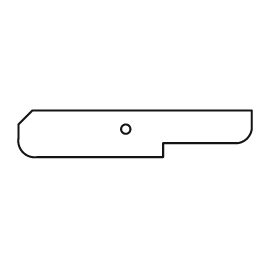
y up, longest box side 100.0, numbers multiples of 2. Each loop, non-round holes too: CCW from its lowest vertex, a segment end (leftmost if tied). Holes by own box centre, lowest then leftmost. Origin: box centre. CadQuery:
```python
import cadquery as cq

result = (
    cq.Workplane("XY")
    .moveTo(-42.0, -10.0)
    .lineTo(12.0, -10.0)
    .lineTo(12.0, -4.0)
    .lineTo(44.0, -4.0)
    .threePointArc((48.0, -2.0), (50.0, 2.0))
    .lineTo(50.0, 10.0)
    .lineTo(-44.0, 10.0)
    .lineTo(-50.0, 4.0)
    .lineTo(-50.0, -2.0)
    .threePointArc((-48.0, -8.0), (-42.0, -10.0))
    .close()
    .moveTo(-4.0, 2.0)
    .circle(2.0)
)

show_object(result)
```